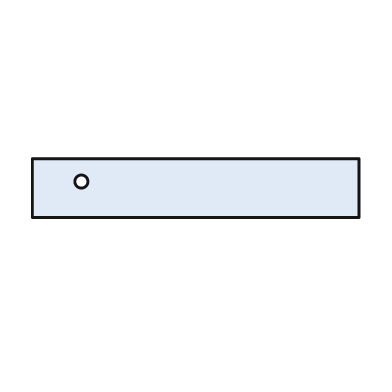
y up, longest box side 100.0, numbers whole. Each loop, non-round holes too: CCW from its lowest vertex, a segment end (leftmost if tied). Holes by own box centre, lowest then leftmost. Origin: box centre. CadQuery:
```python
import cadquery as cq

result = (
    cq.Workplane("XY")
    .moveTo(-50.0, -9.0)
    .lineTo(50.0, -9.0)
    .lineTo(50.0, 9.0)
    .lineTo(-50.0, 9.0)
    .close()
    .moveTo(-35.0, 2.0)
    .circle(2.0)
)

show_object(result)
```